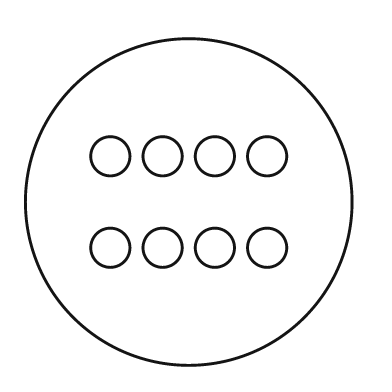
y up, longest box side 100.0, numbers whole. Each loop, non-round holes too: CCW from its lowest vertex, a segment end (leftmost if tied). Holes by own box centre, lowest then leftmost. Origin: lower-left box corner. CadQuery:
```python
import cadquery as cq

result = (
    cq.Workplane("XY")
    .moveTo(50.0, 50.0)
    .circle(50.0)
    .moveTo(26.0, 36.0)
    .circle(6.0)
    .moveTo(42.0, 36.0)
    .circle(6.0)
    .moveTo(58.0, 36.0)
    .circle(6.0)
    .moveTo(74.0, 36.0)
    .circle(6.0)
    .moveTo(26.0, 64.0)
    .circle(6.0)
    .moveTo(42.0, 64.0)
    .circle(6.0)
    .moveTo(58.0, 64.0)
    .circle(6.0)
    .moveTo(74.0, 64.0)
    .circle(6.0)
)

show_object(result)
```